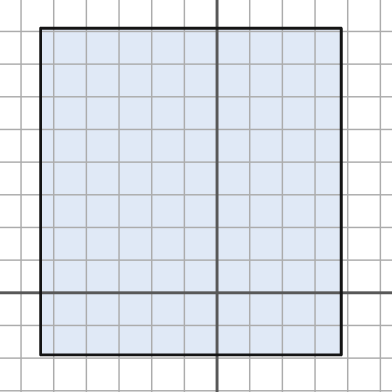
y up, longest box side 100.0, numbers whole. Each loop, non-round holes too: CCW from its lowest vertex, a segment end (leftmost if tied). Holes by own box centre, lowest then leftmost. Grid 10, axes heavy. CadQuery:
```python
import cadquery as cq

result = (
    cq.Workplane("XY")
    .moveTo(-54.0, -19.0)
    .lineTo(38.0, -19.0)
    .lineTo(38.0, 81.0)
    .lineTo(-54.0, 81.0)
    .close()
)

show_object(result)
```